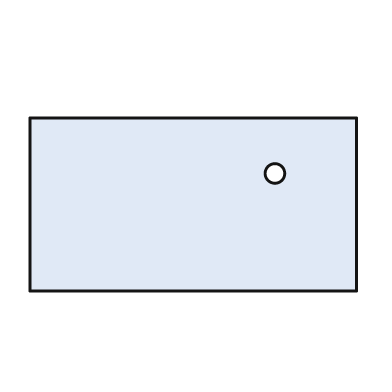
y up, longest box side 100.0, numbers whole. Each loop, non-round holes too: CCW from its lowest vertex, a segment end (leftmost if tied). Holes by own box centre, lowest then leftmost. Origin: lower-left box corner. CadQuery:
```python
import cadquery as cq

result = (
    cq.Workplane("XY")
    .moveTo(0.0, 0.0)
    .lineTo(100.0, 0.0)
    .lineTo(100.0, 53.0)
    .lineTo(0.0, 53.0)
    .close()
    .moveTo(75.0, 36.0)
    .circle(3.0)
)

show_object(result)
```